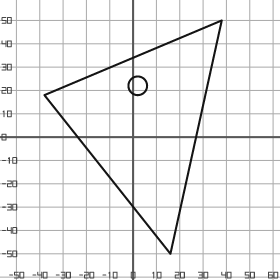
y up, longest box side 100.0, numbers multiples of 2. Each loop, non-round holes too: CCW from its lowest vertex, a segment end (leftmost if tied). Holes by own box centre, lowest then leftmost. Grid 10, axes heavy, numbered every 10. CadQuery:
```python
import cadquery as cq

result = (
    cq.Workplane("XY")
    .moveTo(16.0, -50.0)
    .lineTo(38.0, 50.0)
    .lineTo(-38.0, 18.0)
    .close()
    .moveTo(2.0, 22.0)
    .circle(4.0)
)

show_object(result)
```